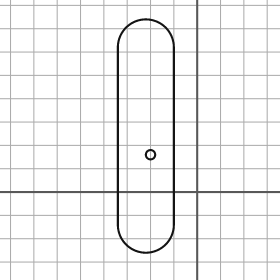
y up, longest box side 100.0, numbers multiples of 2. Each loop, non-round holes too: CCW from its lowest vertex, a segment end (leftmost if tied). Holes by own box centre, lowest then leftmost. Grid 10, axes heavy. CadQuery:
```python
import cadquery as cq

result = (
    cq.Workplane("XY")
    .moveTo(-34.0, -14.0)
    .threePointArc((-22.0, -26.0), (-10.0, -14.0))
    .lineTo(-10.0, 62.0)
    .threePointArc((-22.0, 74.0), (-34.0, 62.0))
    .close()
    .moveTo(-20.0, 16.0)
    .circle(2.0)
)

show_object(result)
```